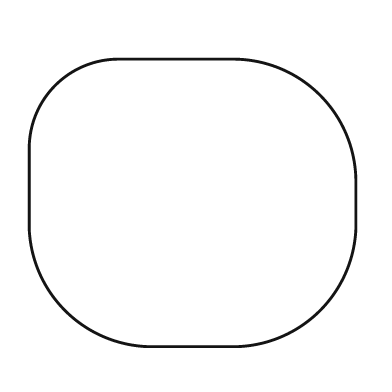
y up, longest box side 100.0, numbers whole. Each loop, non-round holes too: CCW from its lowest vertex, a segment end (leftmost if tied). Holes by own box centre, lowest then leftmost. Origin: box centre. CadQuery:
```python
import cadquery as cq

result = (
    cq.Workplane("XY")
    .moveTo(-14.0, -44.0)
    .lineTo(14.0, -44.0)
    .threePointArc((39.0, -33.0), (50.0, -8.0))
    .lineTo(50.0, 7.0)
    .threePointArc((39.0, 33.0), (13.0, 44.0))
    .lineTo(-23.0, 44.0)
    .threePointArc((-42.0, 36.0), (-50.0, 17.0))
    .lineTo(-50.0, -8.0)
    .threePointArc((-39.0, -33.0), (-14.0, -44.0))
    .close()
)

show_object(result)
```